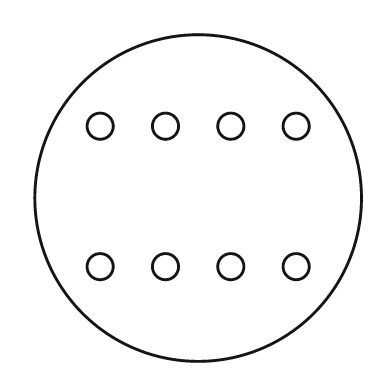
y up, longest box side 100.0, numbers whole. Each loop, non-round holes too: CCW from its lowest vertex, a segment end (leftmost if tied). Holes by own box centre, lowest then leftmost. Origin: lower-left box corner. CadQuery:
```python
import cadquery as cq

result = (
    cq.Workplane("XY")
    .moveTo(50.0, 50.0)
    .circle(50.0)
    .moveTo(20.0, 29.0)
    .circle(4.0)
    .moveTo(40.0, 29.0)
    .circle(4.0)
    .moveTo(60.0, 29.0)
    .circle(4.0)
    .moveTo(80.0, 29.0)
    .circle(4.0)
    .moveTo(20.0, 72.0)
    .circle(4.0)
    .moveTo(40.0, 72.0)
    .circle(4.0)
    .moveTo(60.0, 72.0)
    .circle(4.0)
    .moveTo(80.0, 72.0)
    .circle(4.0)
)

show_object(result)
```